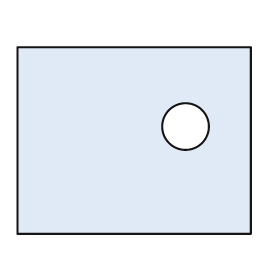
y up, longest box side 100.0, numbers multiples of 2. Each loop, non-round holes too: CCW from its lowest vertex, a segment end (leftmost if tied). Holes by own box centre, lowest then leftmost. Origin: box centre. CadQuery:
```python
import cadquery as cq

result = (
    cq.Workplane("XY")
    .moveTo(-50.0, -40.0)
    .lineTo(50.0, -40.0)
    .lineTo(50.0, 40.0)
    .lineTo(-50.0, 40.0)
    .close()
    .moveTo(22.0, 6.0)
    .circle(10.0)
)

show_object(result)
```